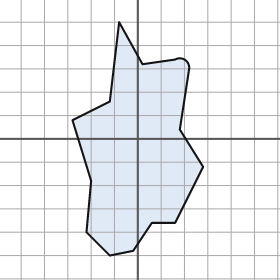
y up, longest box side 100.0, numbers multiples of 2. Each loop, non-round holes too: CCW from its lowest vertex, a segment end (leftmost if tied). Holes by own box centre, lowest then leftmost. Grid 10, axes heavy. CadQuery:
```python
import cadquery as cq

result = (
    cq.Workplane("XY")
    .moveTo(-12.0, -50.0)
    .lineTo(-2.0, -48.0)
    .lineTo(6.0, -36.0)
    .lineTo(16.0, -36.0)
    .lineTo(28.0, -12.0)
    .lineTo(18.0, 4.0)
    .lineTo(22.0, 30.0)
    .threePointArc((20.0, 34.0), (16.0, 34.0))
    .lineTo(2.0, 32.0)
    .lineTo(-8.0, 50.0)
    .lineTo(-12.0, 16.0)
    .lineTo(-28.0, 8.0)
    .lineTo(-20.0, -18.0)
    .lineTo(-22.0, -40.0)
    .close()
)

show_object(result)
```